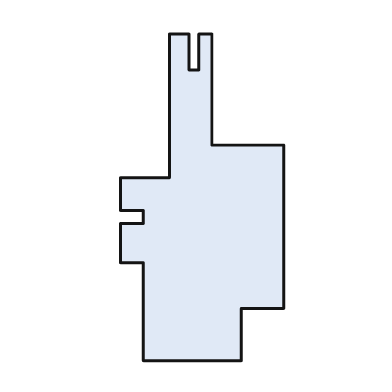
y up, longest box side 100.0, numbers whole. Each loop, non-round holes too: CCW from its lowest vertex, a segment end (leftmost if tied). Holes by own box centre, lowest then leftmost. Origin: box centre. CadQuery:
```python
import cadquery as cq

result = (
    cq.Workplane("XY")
    .moveTo(-18.0, -50.0)
    .lineTo(12.0, -50.0)
    .lineTo(12.0, -34.0)
    .lineTo(25.0, -34.0)
    .lineTo(25.0, 16.0)
    .lineTo(3.0, 16.0)
    .lineTo(3.0, 50.0)
    .lineTo(-1.0, 50.0)
    .lineTo(-1.0, 39.0)
    .lineTo(-4.0, 39.0)
    .lineTo(-4.0, 50.0)
    .lineTo(-10.0, 50.0)
    .lineTo(-10.0, 6.0)
    .lineTo(-25.0, 6.0)
    .lineTo(-25.0, -4.0)
    .lineTo(-18.0, -4.0)
    .lineTo(-18.0, -8.0)
    .lineTo(-25.0, -8.0)
    .lineTo(-25.0, -20.0)
    .lineTo(-18.0, -20.0)
    .close()
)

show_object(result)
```